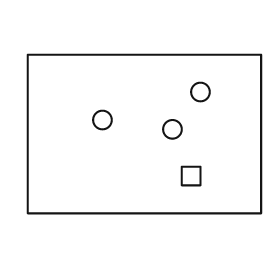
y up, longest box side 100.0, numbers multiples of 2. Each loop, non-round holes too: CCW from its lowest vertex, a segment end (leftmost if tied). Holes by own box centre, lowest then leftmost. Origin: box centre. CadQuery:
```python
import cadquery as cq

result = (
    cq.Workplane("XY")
    .moveTo(-50.0, -34.0)
    .lineTo(50.0, -34.0)
    .lineTo(50.0, 34.0)
    .lineTo(-50.0, 34.0)
    .close()
    .moveTo(16.0, -22.0)
    .lineTo(24.0, -22.0)
    .lineTo(24.0, -14.0)
    .lineTo(16.0, -14.0)
    .close()
    .moveTo(12.0, 2.0)
    .circle(4.0)
    .moveTo(-18.0, 6.0)
    .circle(4.0)
    .moveTo(24.0, 18.0)
    .circle(4.0)
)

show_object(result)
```